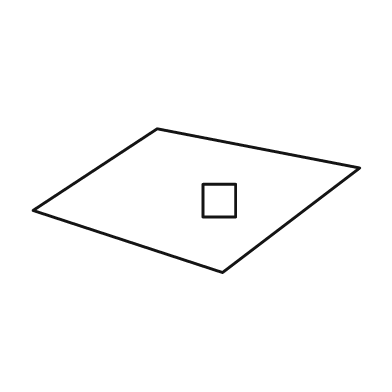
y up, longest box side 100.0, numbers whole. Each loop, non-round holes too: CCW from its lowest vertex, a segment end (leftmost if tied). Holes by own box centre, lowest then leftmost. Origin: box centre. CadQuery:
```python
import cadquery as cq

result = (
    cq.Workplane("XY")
    .moveTo(8.0, -22.0)
    .lineTo(50.0, 10.0)
    .lineTo(-12.0, 22.0)
    .lineTo(-50.0, -3.0)
    .close()
    .moveTo(2.0, -5.0)
    .lineTo(12.0, -5.0)
    .lineTo(12.0, 5.0)
    .lineTo(2.0, 5.0)
    .close()
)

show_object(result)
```